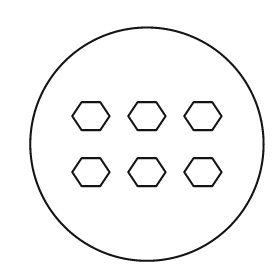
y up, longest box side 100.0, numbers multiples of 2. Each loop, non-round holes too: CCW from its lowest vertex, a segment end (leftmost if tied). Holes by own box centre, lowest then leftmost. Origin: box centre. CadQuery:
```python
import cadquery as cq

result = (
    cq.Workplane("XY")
    .moveTo(0.0, 0.0)
    .circle(50.0)
    .moveTo(-28.0, -18.0)
    .lineTo(-20.0, -18.0)
    .lineTo(-16.0, -12.0)
    .lineTo(-20.0, -6.0)
    .lineTo(-28.0, -6.0)
    .lineTo(-32.0, -12.0)
    .close()
    .moveTo(-4.0, -18.0)
    .lineTo(4.0, -18.0)
    .lineTo(8.0, -12.0)
    .lineTo(4.0, -6.0)
    .lineTo(-4.0, -6.0)
    .lineTo(-8.0, -12.0)
    .close()
    .moveTo(20.0, -18.0)
    .lineTo(28.0, -18.0)
    .lineTo(32.0, -12.0)
    .lineTo(28.0, -6.0)
    .lineTo(20.0, -6.0)
    .lineTo(16.0, -12.0)
    .close()
    .moveTo(-28.0, 6.0)
    .lineTo(-20.0, 6.0)
    .lineTo(-16.0, 12.0)
    .lineTo(-20.0, 18.0)
    .lineTo(-28.0, 18.0)
    .lineTo(-32.0, 12.0)
    .close()
    .moveTo(-4.0, 6.0)
    .lineTo(4.0, 6.0)
    .lineTo(8.0, 12.0)
    .lineTo(4.0, 18.0)
    .lineTo(-4.0, 18.0)
    .lineTo(-8.0, 12.0)
    .close()
    .moveTo(20.0, 6.0)
    .lineTo(28.0, 6.0)
    .lineTo(32.0, 12.0)
    .lineTo(28.0, 18.0)
    .lineTo(20.0, 18.0)
    .lineTo(16.0, 12.0)
    .close()
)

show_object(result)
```